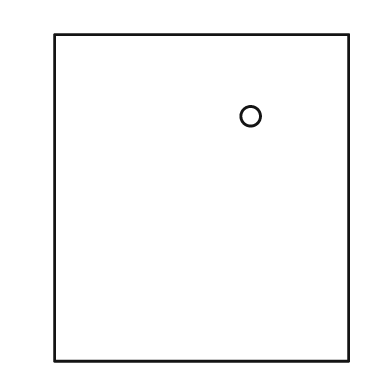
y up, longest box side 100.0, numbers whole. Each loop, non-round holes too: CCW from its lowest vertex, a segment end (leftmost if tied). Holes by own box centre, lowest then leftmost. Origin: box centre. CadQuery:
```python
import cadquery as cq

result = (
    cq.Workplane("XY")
    .moveTo(-45.0, -50.0)
    .lineTo(45.0, -50.0)
    .lineTo(45.0, 50.0)
    .lineTo(-45.0, 50.0)
    .close()
    .moveTo(15.0, 25.0)
    .circle(3.0)
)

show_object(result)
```